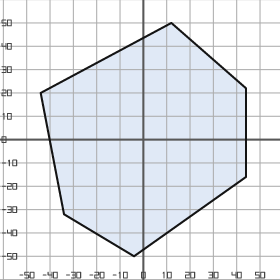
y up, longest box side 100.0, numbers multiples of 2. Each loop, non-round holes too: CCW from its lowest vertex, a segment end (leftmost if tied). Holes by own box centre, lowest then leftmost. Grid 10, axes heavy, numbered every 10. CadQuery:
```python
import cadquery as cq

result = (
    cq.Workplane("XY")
    .moveTo(-4.0, -50.0)
    .lineTo(44.0, -16.0)
    .lineTo(44.0, 22.0)
    .lineTo(12.0, 50.0)
    .lineTo(-44.0, 20.0)
    .lineTo(-34.0, -32.0)
    .close()
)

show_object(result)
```